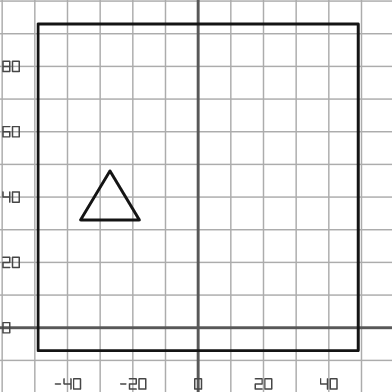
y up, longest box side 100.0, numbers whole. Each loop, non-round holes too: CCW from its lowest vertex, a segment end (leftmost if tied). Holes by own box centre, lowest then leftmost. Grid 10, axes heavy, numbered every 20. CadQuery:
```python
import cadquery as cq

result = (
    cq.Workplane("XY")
    .moveTo(-49.0, -7.0)
    .lineTo(49.0, -7.0)
    .lineTo(49.0, 93.0)
    .lineTo(-49.0, 93.0)
    .close()
    .moveTo(-36.0, 33.0)
    .lineTo(-18.0, 33.0)
    .lineTo(-27.0, 48.0)
    .close()
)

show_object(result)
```